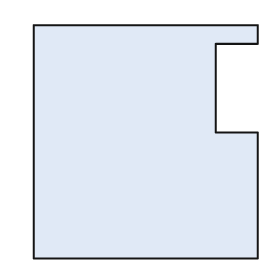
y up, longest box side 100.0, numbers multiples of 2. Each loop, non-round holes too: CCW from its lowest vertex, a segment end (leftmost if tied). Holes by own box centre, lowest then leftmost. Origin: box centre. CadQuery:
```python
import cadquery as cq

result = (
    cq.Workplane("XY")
    .moveTo(-48.0, -50.0)
    .lineTo(48.0, -50.0)
    .lineTo(48.0, 4.0)
    .lineTo(30.0, 4.0)
    .lineTo(30.0, 42.0)
    .lineTo(48.0, 42.0)
    .lineTo(48.0, 50.0)
    .lineTo(-48.0, 50.0)
    .close()
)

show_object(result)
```